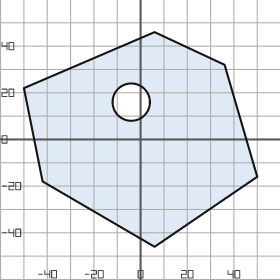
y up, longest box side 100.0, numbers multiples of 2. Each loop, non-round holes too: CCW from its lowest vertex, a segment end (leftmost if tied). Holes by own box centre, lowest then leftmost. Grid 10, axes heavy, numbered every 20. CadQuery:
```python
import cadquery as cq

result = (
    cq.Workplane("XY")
    .moveTo(6.0, -46.0)
    .lineTo(50.0, -16.0)
    .lineTo(36.0, 32.0)
    .lineTo(6.0, 46.0)
    .lineTo(-50.0, 22.0)
    .lineTo(-42.0, -18.0)
    .close()
    .moveTo(-4.0, 16.0)
    .circle(8.0)
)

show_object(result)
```